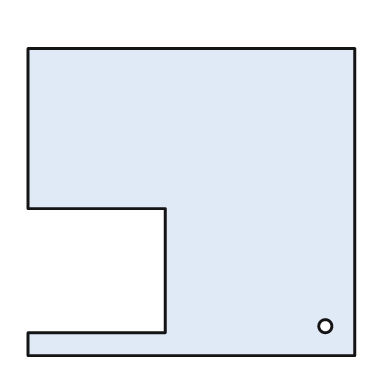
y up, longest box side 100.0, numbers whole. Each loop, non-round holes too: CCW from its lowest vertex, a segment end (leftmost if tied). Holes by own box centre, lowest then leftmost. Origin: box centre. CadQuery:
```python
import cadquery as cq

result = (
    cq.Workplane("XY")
    .moveTo(-50.0, -47.0)
    .lineTo(50.0, -47.0)
    .lineTo(50.0, 47.0)
    .lineTo(-50.0, 47.0)
    .lineTo(-50.0, -2.0)
    .lineTo(-8.0, -2.0)
    .lineTo(-8.0, -40.0)
    .lineTo(-50.0, -40.0)
    .close()
    .moveTo(41.0, -38.0)
    .circle(2.0)
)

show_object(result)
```